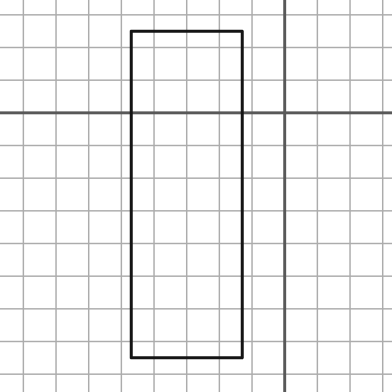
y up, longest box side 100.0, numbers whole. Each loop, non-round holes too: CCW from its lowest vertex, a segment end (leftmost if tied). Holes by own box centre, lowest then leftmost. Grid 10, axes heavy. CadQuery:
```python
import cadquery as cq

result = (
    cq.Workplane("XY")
    .moveTo(-47.0, -75.0)
    .lineTo(-13.0, -75.0)
    .lineTo(-13.0, 25.0)
    .lineTo(-47.0, 25.0)
    .close()
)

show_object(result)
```